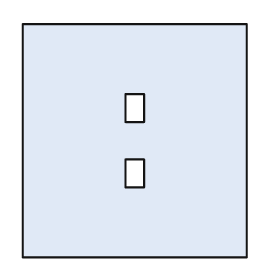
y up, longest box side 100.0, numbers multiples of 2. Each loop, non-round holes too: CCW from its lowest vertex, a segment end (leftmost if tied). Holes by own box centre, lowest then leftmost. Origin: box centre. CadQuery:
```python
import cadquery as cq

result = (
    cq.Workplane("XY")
    .moveTo(-48.0, -50.0)
    .lineTo(48.0, -50.0)
    .lineTo(48.0, 50.0)
    .lineTo(-48.0, 50.0)
    .close()
    .moveTo(-4.0, -20.0)
    .lineTo(4.0, -20.0)
    .lineTo(4.0, -8.0)
    .lineTo(-4.0, -8.0)
    .close()
    .moveTo(-4.0, 8.0)
    .lineTo(4.0, 8.0)
    .lineTo(4.0, 20.0)
    .lineTo(-4.0, 20.0)
    .close()
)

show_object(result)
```